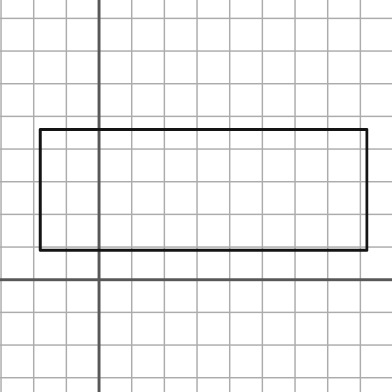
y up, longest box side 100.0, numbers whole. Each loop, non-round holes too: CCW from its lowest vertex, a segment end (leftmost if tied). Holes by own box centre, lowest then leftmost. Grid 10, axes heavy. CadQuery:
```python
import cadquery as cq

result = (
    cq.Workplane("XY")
    .moveTo(-18.0, 9.0)
    .lineTo(82.0, 9.0)
    .lineTo(82.0, 46.0)
    .lineTo(-18.0, 46.0)
    .close()
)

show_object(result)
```